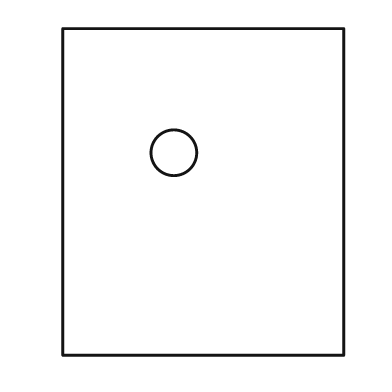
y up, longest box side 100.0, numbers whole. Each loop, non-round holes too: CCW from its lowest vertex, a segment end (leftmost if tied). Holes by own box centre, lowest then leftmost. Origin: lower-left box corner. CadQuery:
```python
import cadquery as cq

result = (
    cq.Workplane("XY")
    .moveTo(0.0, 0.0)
    .lineTo(86.0, 0.0)
    .lineTo(86.0, 100.0)
    .lineTo(0.0, 100.0)
    .close()
    .moveTo(34.0, 62.0)
    .circle(7.0)
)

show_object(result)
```